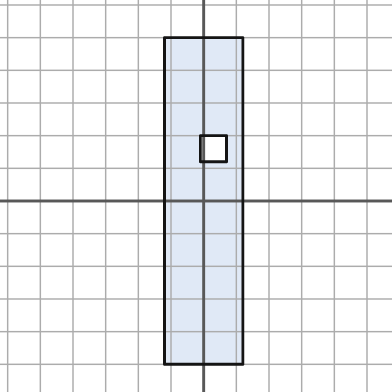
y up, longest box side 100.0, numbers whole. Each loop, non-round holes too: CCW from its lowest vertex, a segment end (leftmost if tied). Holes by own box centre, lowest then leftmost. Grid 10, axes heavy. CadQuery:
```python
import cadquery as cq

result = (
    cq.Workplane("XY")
    .moveTo(-12.0, -50.0)
    .lineTo(12.0, -50.0)
    .lineTo(12.0, 50.0)
    .lineTo(-12.0, 50.0)
    .close()
    .moveTo(-1.0, 12.0)
    .lineTo(7.0, 12.0)
    .lineTo(7.0, 20.0)
    .lineTo(-1.0, 20.0)
    .close()
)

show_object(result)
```